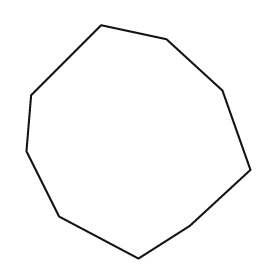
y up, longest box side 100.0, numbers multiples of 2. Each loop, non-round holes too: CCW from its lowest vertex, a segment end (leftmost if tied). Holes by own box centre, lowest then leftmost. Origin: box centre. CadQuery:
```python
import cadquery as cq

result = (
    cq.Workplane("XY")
    .moveTo(0.0, -50.0)
    .lineTo(22.0, -36.0)
    .lineTo(48.0, -12.0)
    .lineTo(36.0, 22.0)
    .lineTo(12.0, 44.0)
    .lineTo(-16.0, 50.0)
    .lineTo(-46.0, 20.0)
    .lineTo(-48.0, -4.0)
    .lineTo(-34.0, -32.0)
    .close()
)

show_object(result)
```